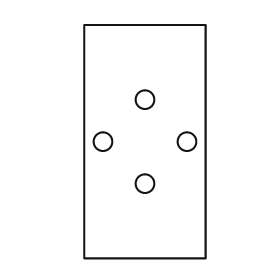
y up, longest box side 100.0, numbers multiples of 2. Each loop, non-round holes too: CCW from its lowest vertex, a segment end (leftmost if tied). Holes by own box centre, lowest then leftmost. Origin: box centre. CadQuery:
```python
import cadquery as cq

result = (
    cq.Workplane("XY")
    .moveTo(-26.0, -50.0)
    .lineTo(26.0, -50.0)
    .lineTo(26.0, 50.0)
    .lineTo(-26.0, 50.0)
    .close()
    .moveTo(0.0, -18.0)
    .circle(4.0)
    .moveTo(-18.0, 0.0)
    .circle(4.0)
    .moveTo(18.0, 0.0)
    .circle(4.0)
    .moveTo(0.0, 18.0)
    .circle(4.0)
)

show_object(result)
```